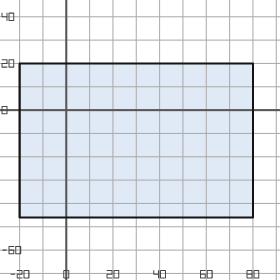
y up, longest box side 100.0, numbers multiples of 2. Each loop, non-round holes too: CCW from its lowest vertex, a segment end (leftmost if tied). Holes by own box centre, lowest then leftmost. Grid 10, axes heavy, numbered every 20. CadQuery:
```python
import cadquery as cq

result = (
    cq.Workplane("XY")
    .moveTo(-20.0, -46.0)
    .lineTo(80.0, -46.0)
    .lineTo(80.0, 20.0)
    .lineTo(-20.0, 20.0)
    .close()
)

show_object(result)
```